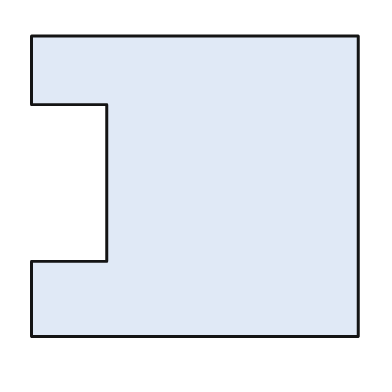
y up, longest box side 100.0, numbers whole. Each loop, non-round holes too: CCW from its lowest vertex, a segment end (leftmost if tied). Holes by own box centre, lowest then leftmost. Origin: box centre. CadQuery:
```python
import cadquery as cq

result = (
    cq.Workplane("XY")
    .moveTo(-50.0, -46.0)
    .lineTo(50.0, -46.0)
    .lineTo(50.0, 46.0)
    .lineTo(-50.0, 46.0)
    .lineTo(-50.0, 25.0)
    .lineTo(-27.0, 25.0)
    .lineTo(-27.0, -23.0)
    .lineTo(-50.0, -23.0)
    .close()
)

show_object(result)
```